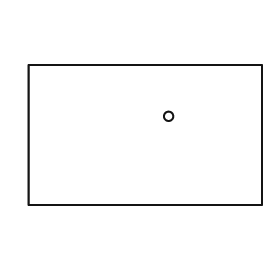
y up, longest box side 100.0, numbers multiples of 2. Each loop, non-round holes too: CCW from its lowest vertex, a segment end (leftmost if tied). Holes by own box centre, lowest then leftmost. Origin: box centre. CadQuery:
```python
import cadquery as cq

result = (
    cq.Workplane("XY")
    .moveTo(-50.0, -30.0)
    .lineTo(50.0, -30.0)
    .lineTo(50.0, 30.0)
    .lineTo(-50.0, 30.0)
    .close()
    .moveTo(10.0, 8.0)
    .circle(2.0)
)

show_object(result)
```